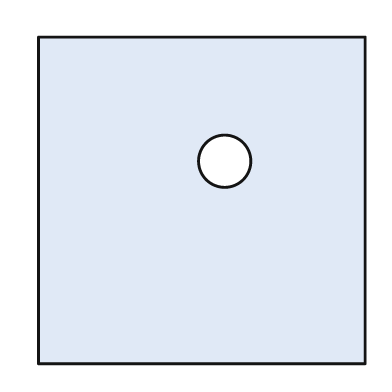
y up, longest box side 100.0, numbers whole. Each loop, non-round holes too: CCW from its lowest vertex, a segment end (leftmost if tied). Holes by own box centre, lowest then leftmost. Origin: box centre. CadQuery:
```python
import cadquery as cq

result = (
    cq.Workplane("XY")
    .moveTo(-50.0, -50.0)
    .lineTo(50.0, -50.0)
    .lineTo(50.0, 50.0)
    .lineTo(-50.0, 50.0)
    .close()
    .moveTo(7.0, 12.0)
    .circle(8.0)
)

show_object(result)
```